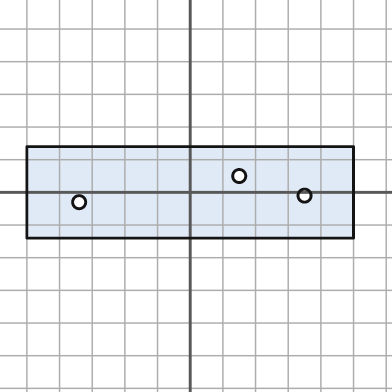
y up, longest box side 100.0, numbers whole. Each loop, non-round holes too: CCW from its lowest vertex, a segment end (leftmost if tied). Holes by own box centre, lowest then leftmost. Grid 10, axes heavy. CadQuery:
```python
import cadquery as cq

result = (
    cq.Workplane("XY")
    .moveTo(-50.0, -14.0)
    .lineTo(50.0, -14.0)
    .lineTo(50.0, 14.0)
    .lineTo(-50.0, 14.0)
    .close()
    .moveTo(-34.0, -3.0)
    .circle(2.0)
    .moveTo(35.0, -1.0)
    .circle(2.0)
    .moveTo(15.0, 5.0)
    .circle(2.0)
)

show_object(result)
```